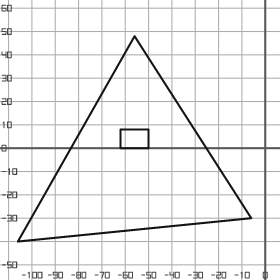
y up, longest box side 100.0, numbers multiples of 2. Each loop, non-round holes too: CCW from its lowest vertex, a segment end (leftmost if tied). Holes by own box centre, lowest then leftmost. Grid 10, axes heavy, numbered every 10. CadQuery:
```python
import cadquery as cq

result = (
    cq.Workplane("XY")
    .moveTo(-106.0, -40.0)
    .lineTo(-6.0, -30.0)
    .lineTo(-56.0, 48.0)
    .close()
    .moveTo(-62.0, 0.0)
    .lineTo(-50.0, 0.0)
    .lineTo(-50.0, 8.0)
    .lineTo(-62.0, 8.0)
    .close()
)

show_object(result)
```